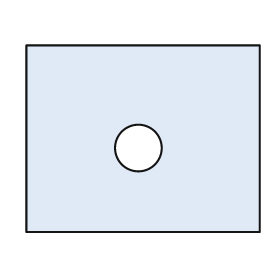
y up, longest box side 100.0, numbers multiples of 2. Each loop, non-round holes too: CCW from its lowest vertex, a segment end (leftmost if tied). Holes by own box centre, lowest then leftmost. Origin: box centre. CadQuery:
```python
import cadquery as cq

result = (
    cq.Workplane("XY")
    .moveTo(-50.0, -40.0)
    .lineTo(50.0, -40.0)
    .lineTo(50.0, 40.0)
    .lineTo(-50.0, 40.0)
    .close()
    .moveTo(-2.0, -4.0)
    .circle(10.0)
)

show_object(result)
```